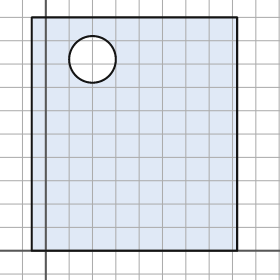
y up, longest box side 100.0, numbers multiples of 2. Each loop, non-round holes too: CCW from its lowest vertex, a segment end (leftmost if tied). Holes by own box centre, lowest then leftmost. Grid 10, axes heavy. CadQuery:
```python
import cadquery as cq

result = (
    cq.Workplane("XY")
    .moveTo(-6.0, 0.0)
    .lineTo(82.0, 0.0)
    .lineTo(82.0, 100.0)
    .lineTo(-6.0, 100.0)
    .close()
    .moveTo(20.0, 82.0)
    .circle(10.0)
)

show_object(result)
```